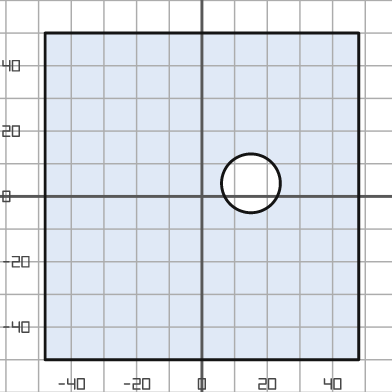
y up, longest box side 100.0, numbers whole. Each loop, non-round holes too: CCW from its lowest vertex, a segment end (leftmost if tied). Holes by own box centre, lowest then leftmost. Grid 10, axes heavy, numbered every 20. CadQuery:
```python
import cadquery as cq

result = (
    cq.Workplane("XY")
    .moveTo(-48.0, -50.0)
    .lineTo(48.0, -50.0)
    .lineTo(48.0, 50.0)
    .lineTo(-48.0, 50.0)
    .close()
    .moveTo(15.0, 4.0)
    .circle(9.0)
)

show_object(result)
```